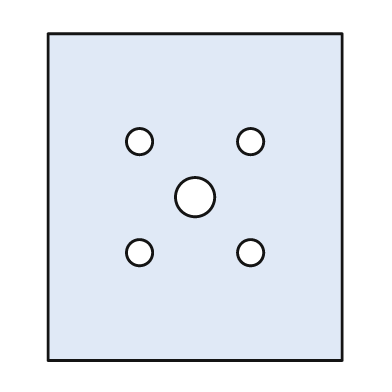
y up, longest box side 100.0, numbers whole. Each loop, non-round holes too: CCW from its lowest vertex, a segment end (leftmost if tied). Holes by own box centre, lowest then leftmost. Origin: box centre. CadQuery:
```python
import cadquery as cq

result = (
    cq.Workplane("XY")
    .moveTo(-45.0, -50.0)
    .lineTo(45.0, -50.0)
    .lineTo(45.0, 50.0)
    .lineTo(-45.0, 50.0)
    .close()
    .moveTo(-17.0, -17.0)
    .circle(4.0)
    .moveTo(17.0, -17.0)
    .circle(4.0)
    .moveTo(0.0, 0.0)
    .circle(6.0)
    .moveTo(-17.0, 17.0)
    .circle(4.0)
    .moveTo(17.0, 17.0)
    .circle(4.0)
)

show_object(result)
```